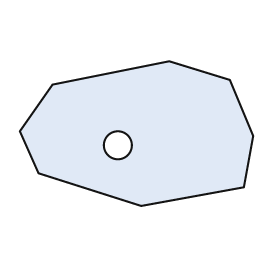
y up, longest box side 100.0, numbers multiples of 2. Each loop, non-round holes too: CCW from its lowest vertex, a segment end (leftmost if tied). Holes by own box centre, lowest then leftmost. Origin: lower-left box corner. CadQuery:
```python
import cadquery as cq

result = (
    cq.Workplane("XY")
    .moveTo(52.0, 0.0)
    .lineTo(96.0, 8.0)
    .lineTo(100.0, 30.0)
    .lineTo(90.0, 54.0)
    .lineTo(64.0, 62.0)
    .lineTo(14.0, 52.0)
    .lineTo(0.0, 32.0)
    .lineTo(8.0, 14.0)
    .close()
    .moveTo(42.0, 26.0)
    .circle(6.0)
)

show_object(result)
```